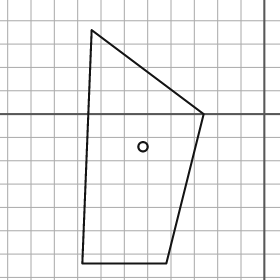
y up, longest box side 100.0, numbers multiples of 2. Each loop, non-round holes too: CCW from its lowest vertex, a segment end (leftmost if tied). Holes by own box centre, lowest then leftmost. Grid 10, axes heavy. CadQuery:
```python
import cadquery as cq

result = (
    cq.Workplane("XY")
    .moveTo(-78.0, -64.0)
    .lineTo(-42.0, -64.0)
    .lineTo(-26.0, 0.0)
    .lineTo(-74.0, 36.0)
    .close()
    .moveTo(-52.0, -14.0)
    .circle(2.0)
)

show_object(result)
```